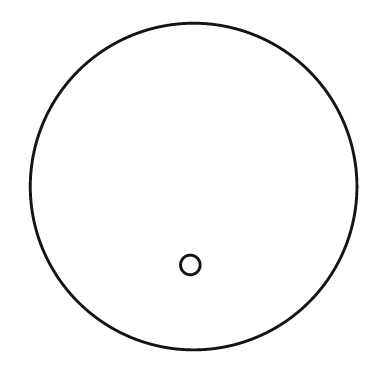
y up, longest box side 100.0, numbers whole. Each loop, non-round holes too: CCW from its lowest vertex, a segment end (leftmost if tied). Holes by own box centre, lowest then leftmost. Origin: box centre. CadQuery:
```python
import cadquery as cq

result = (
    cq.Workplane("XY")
    .moveTo(0.0, 0.0)
    .circle(50.0)
    .moveTo(-1.0, -24.0)
    .circle(3.0)
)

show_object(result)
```